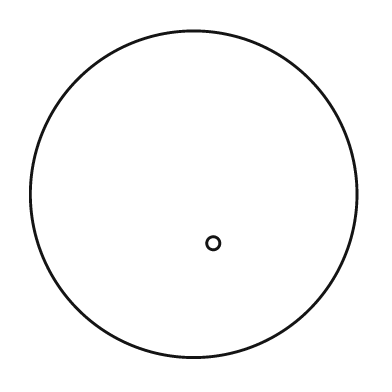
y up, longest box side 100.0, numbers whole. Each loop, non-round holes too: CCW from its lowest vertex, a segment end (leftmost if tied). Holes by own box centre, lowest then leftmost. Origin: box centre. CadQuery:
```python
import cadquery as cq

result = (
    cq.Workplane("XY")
    .moveTo(0.0, 0.0)
    .circle(50.0)
    .moveTo(6.0, -15.0)
    .circle(2.0)
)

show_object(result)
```